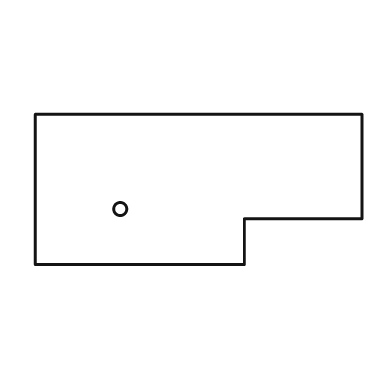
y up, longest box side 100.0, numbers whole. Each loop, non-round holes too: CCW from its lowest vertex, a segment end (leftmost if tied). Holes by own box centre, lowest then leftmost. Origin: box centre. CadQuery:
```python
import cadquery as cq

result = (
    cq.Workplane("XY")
    .moveTo(-50.0, -23.0)
    .lineTo(14.0, -23.0)
    .lineTo(14.0, -9.0)
    .lineTo(50.0, -9.0)
    .lineTo(50.0, 23.0)
    .lineTo(-50.0, 23.0)
    .close()
    .moveTo(-24.0, -6.0)
    .circle(2.0)
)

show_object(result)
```